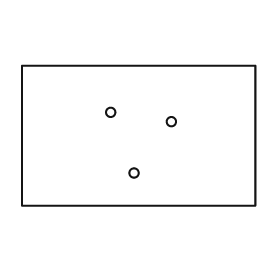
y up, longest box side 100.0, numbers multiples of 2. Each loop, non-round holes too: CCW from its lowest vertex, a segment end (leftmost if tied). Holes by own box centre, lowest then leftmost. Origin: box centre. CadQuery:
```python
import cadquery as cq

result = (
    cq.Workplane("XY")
    .moveTo(-50.0, -30.0)
    .lineTo(50.0, -30.0)
    .lineTo(50.0, 30.0)
    .lineTo(-50.0, 30.0)
    .close()
    .moveTo(-2.0, -16.0)
    .circle(2.0)
    .moveTo(14.0, 6.0)
    .circle(2.0)
    .moveTo(-12.0, 10.0)
    .circle(2.0)
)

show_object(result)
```